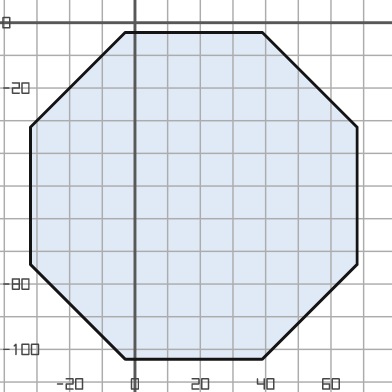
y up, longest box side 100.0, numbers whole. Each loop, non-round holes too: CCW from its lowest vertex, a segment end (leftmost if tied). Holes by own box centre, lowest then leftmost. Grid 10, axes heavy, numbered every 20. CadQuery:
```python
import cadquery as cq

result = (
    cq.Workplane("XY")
    .moveTo(-3.0, -103.0)
    .lineTo(39.0, -103.0)
    .lineTo(68.0, -74.0)
    .lineTo(68.0, -32.0)
    .lineTo(39.0, -3.0)
    .lineTo(-3.0, -3.0)
    .lineTo(-32.0, -32.0)
    .lineTo(-32.0, -74.0)
    .close()
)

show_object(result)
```